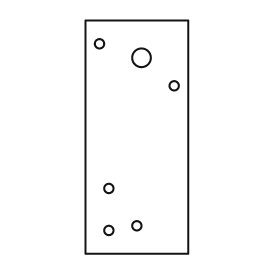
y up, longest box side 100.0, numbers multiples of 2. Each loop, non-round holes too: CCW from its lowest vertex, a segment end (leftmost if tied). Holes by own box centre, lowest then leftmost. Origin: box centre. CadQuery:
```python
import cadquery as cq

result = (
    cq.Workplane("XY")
    .moveTo(-22.0, -50.0)
    .lineTo(22.0, -50.0)
    .lineTo(22.0, 50.0)
    .lineTo(-22.0, 50.0)
    .close()
    .moveTo(-12.0, -40.0)
    .circle(2.0)
    .moveTo(0.0, -38.0)
    .circle(2.0)
    .moveTo(-12.0, -22.0)
    .circle(2.0)
    .moveTo(16.0, 22.0)
    .circle(2.0)
    .moveTo(2.0, 34.0)
    .circle(4.0)
    .moveTo(-16.0, 40.0)
    .circle(2.0)
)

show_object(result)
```